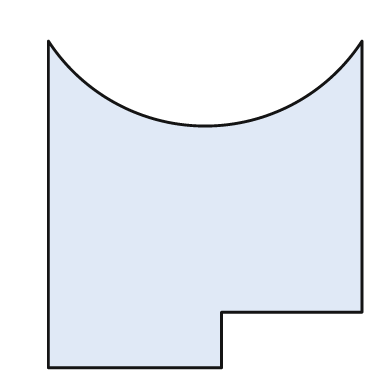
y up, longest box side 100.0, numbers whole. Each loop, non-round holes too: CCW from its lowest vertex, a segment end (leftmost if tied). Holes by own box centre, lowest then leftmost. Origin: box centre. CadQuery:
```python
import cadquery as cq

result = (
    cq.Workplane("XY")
    .moveTo(-48.0, -50.0)
    .lineTo(5.0, -50.0)
    .lineTo(5.0, -33.0)
    .lineTo(48.0, -33.0)
    .lineTo(48.0, 50.0)
    .threePointArc((0.0, 24.0), (-48.0, 50.0))
    .close()
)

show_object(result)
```